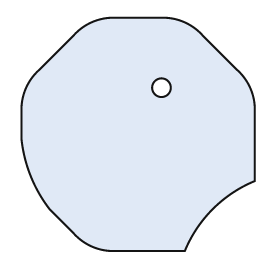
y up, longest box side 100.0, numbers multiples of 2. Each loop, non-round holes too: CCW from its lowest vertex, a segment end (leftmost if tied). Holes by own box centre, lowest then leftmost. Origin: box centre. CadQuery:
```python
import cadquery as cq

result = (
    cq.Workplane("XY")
    .moveTo(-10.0, -50.0)
    .lineTo(20.0, -50.0)
    .threePointArc((32.0, -32.0), (50.0, -20.0))
    .lineTo(50.0, 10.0)
    .threePointArc((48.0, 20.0), (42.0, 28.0))
    .lineTo(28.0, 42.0)
    .threePointArc((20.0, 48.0), (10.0, 50.0))
    .lineTo(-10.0, 50.0)
    .threePointArc((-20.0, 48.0), (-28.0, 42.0))
    .lineTo(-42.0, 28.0)
    .threePointArc((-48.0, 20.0), (-50.0, 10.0))
    .lineTo(-50.0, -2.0)
    .threePointArc((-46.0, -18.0), (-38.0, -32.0))
    .lineTo(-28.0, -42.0)
    .threePointArc((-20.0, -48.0), (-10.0, -50.0))
    .close()
    .moveTo(10.0, 20.0)
    .circle(4.0)
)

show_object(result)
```